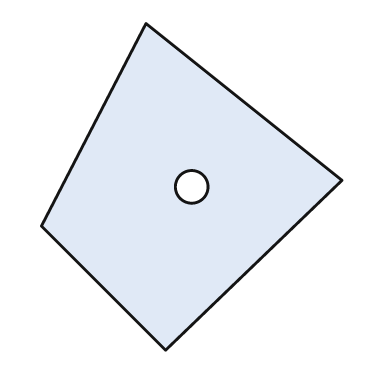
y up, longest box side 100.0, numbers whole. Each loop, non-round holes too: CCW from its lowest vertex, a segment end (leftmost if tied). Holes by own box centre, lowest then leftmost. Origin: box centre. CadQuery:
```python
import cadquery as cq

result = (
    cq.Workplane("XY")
    .moveTo(-8.0, -50.0)
    .lineTo(46.0, 2.0)
    .lineTo(-14.0, 50.0)
    .lineTo(-46.0, -12.0)
    .close()
    .moveTo(0.0, 0.0)
    .circle(5.0)
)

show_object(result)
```